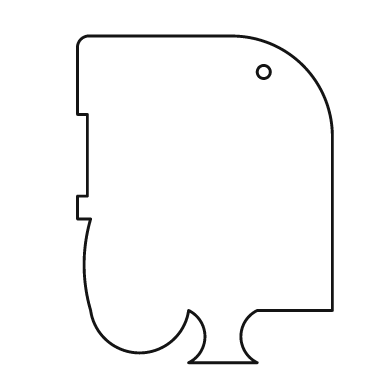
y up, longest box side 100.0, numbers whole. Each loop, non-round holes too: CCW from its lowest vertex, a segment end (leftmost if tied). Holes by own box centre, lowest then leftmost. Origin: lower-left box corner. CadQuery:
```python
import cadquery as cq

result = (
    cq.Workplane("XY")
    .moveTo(34.0, 0.0)
    .lineTo(55.0, 0.0)
    .threePointArc((50.0, 8.0), (55.0, 16.0))
    .lineTo(78.0, 16.0)
    .lineTo(78.0, 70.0)
    .threePointArc((69.0, 91.0), (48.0, 100.0))
    .lineTo(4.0, 100.0)
    .threePointArc((1.0, 99.0), (0.0, 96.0))
    .lineTo(0.0, 76.0)
    .lineTo(3.0, 76.0)
    .lineTo(3.0, 51.0)
    .lineTo(0.0, 51.0)
    .lineTo(0.0, 44.0)
    .lineTo(4.0, 44.0)
    .threePointArc((2.0, 30.0), (4.0, 16.0))
    .threePointArc((19.0, 3.0), (34.0, 16.0))
    .threePointArc((39.0, 8.0), (34.0, 0.0))
    .close()
    .moveTo(57.0, 89.0)
    .circle(2.0)
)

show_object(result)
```